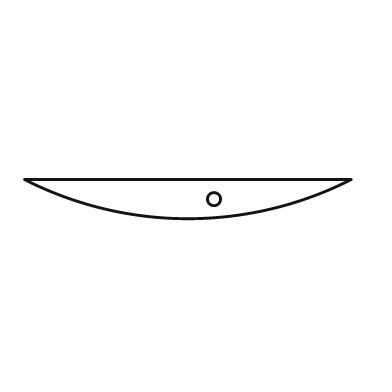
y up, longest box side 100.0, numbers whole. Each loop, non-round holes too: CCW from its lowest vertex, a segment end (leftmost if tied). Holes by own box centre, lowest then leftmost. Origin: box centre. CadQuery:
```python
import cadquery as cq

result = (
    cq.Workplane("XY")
    .moveTo(-50.0, 6.0)
    .threePointArc((0.0, -6.0), (50.0, 6.0))
    .close()
    .moveTo(8.0, 0.0)
    .circle(2.0)
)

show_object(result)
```